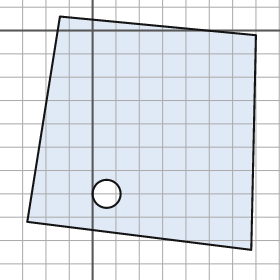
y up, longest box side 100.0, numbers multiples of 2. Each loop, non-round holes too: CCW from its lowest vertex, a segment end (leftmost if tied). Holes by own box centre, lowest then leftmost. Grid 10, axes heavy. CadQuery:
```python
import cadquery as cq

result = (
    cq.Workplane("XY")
    .moveTo(68.0, -94.0)
    .lineTo(70.0, -2.0)
    .lineTo(-14.0, 6.0)
    .lineTo(-28.0, -82.0)
    .close()
    .moveTo(6.0, -70.0)
    .circle(6.0)
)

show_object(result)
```